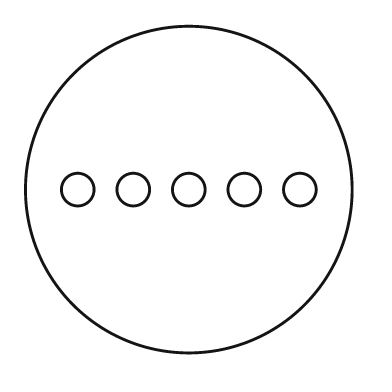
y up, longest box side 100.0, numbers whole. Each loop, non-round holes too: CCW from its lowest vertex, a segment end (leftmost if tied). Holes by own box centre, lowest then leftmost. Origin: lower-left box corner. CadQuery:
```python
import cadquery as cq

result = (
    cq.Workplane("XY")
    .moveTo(50.0, 50.0)
    .circle(50.0)
    .moveTo(16.0, 50.0)
    .circle(5.0)
    .moveTo(33.0, 50.0)
    .circle(5.0)
    .moveTo(50.0, 50.0)
    .circle(5.0)
    .moveTo(67.0, 50.0)
    .circle(5.0)
    .moveTo(84.0, 50.0)
    .circle(5.0)
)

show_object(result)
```